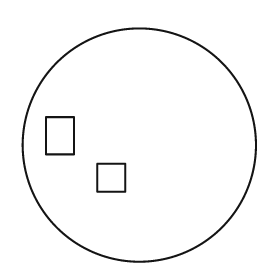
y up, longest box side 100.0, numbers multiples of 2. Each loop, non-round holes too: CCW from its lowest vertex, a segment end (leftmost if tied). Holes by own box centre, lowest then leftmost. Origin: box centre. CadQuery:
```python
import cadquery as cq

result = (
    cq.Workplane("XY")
    .moveTo(0.0, 0.0)
    .circle(50.0)
    .moveTo(-18.0, -20.0)
    .lineTo(-6.0, -20.0)
    .lineTo(-6.0, -8.0)
    .lineTo(-18.0, -8.0)
    .close()
    .moveTo(-40.0, -4.0)
    .lineTo(-28.0, -4.0)
    .lineTo(-28.0, 12.0)
    .lineTo(-40.0, 12.0)
    .close()
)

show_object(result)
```